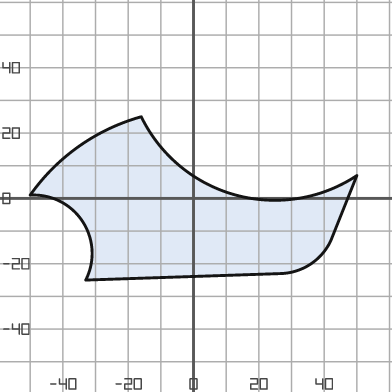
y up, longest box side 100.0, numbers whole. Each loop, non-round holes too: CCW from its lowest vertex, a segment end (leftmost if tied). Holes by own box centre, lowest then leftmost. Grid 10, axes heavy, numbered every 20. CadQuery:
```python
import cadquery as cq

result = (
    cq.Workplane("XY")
    .moveTo(-33.0, -25.0)
    .lineTo(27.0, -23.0)
    .threePointArc((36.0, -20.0), (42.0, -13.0))
    .lineTo(50.0, 7.0)
    .threePointArc((13.0, 1.0), (-16.0, 25.0))
    .threePointArc((-35.0, 16.0), (-50.0, 1.0))
    .threePointArc((-34.0, -7.0), (-33.0, -25.0))
    .close()
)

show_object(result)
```